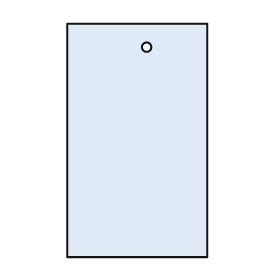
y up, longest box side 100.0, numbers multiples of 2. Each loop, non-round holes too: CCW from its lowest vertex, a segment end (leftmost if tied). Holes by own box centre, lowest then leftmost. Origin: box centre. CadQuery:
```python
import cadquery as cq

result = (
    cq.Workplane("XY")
    .moveTo(-30.0, -50.0)
    .lineTo(30.0, -50.0)
    .lineTo(30.0, 50.0)
    .lineTo(-30.0, 50.0)
    .close()
    .moveTo(4.0, 40.0)
    .circle(2.0)
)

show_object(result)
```